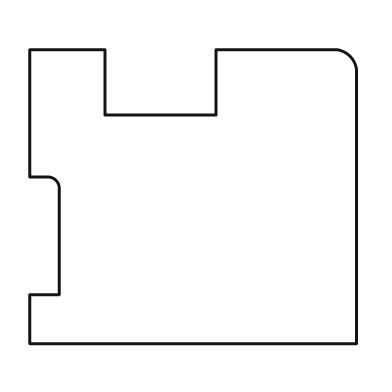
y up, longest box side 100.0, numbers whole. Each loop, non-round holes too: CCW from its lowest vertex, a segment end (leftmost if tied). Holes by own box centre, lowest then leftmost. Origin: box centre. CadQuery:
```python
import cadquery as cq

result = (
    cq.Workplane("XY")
    .moveTo(-50.0, -45.0)
    .lineTo(50.0, -45.0)
    .lineTo(50.0, 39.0)
    .threePointArc((48.0, 43.0), (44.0, 45.0))
    .lineTo(7.0, 45.0)
    .lineTo(7.0, 25.0)
    .lineTo(-27.0, 25.0)
    .lineTo(-27.0, 45.0)
    .lineTo(-50.0, 45.0)
    .lineTo(-50.0, 6.0)
    .lineTo(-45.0, 6.0)
    .threePointArc((-42.0, 5.0), (-41.0, 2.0))
    .lineTo(-41.0, -30.0)
    .lineTo(-50.0, -30.0)
    .close()
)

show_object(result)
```